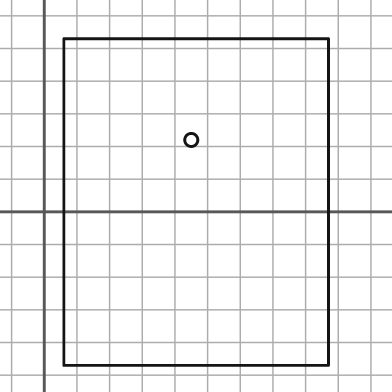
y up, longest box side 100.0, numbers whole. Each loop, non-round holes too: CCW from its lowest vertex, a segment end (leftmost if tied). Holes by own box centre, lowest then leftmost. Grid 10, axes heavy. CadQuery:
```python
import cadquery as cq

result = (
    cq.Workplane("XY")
    .moveTo(6.0, -47.0)
    .lineTo(87.0, -47.0)
    .lineTo(87.0, 53.0)
    .lineTo(6.0, 53.0)
    .close()
    .moveTo(45.0, 22.0)
    .circle(2.0)
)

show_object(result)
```